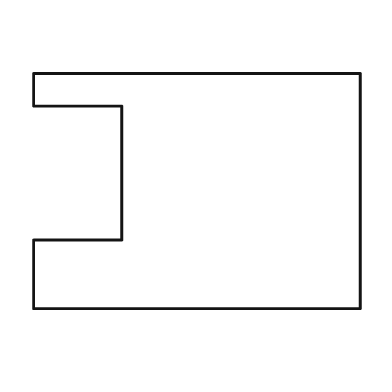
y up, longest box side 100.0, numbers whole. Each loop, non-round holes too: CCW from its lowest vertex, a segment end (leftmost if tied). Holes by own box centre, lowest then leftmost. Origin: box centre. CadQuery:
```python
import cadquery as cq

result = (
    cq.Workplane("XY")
    .moveTo(-50.0, -36.0)
    .lineTo(50.0, -36.0)
    .lineTo(50.0, 36.0)
    .lineTo(-50.0, 36.0)
    .lineTo(-50.0, 26.0)
    .lineTo(-23.0, 26.0)
    .lineTo(-23.0, -15.0)
    .lineTo(-50.0, -15.0)
    .close()
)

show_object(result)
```